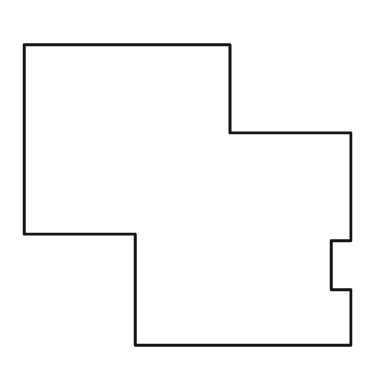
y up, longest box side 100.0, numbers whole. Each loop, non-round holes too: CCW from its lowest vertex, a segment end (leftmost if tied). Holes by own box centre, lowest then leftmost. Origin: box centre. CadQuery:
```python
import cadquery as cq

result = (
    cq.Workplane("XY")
    .moveTo(-16.0, -46.0)
    .lineTo(50.0, -46.0)
    .lineTo(50.0, -29.0)
    .lineTo(44.0, -29.0)
    .lineTo(44.0, -14.0)
    .lineTo(50.0, -14.0)
    .lineTo(50.0, 19.0)
    .lineTo(13.0, 19.0)
    .lineTo(13.0, 46.0)
    .lineTo(-50.0, 46.0)
    .lineTo(-50.0, -12.0)
    .lineTo(-16.0, -12.0)
    .close()
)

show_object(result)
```